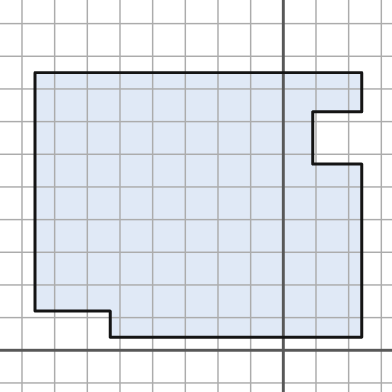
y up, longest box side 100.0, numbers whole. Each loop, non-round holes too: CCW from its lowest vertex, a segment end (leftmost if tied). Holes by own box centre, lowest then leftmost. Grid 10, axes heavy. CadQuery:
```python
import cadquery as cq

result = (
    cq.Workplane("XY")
    .moveTo(-53.0, 4.0)
    .lineTo(24.0, 4.0)
    .lineTo(24.0, 57.0)
    .lineTo(9.0, 57.0)
    .lineTo(9.0, 73.0)
    .lineTo(24.0, 73.0)
    .lineTo(24.0, 85.0)
    .lineTo(-76.0, 85.0)
    .lineTo(-76.0, 12.0)
    .lineTo(-53.0, 12.0)
    .close()
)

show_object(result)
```